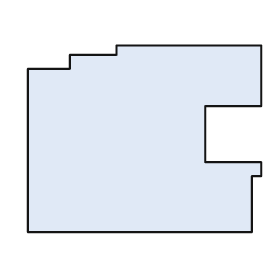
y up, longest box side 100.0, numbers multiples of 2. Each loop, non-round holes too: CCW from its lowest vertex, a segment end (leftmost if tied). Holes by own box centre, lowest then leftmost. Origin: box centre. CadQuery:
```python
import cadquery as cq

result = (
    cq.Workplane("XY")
    .moveTo(-50.0, -40.0)
    .lineTo(46.0, -40.0)
    .lineTo(46.0, -16.0)
    .lineTo(50.0, -16.0)
    .lineTo(50.0, -10.0)
    .lineTo(26.0, -10.0)
    .lineTo(26.0, 14.0)
    .lineTo(50.0, 14.0)
    .lineTo(50.0, 40.0)
    .lineTo(-12.0, 40.0)
    .lineTo(-12.0, 36.0)
    .lineTo(-32.0, 36.0)
    .lineTo(-32.0, 30.0)
    .lineTo(-50.0, 30.0)
    .close()
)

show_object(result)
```